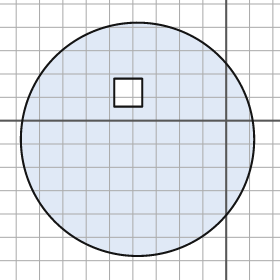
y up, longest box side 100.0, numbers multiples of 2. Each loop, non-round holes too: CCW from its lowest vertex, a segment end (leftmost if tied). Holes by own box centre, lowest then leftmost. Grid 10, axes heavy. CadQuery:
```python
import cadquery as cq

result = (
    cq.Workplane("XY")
    .moveTo(-38.0, -8.0)
    .circle(50.0)
    .moveTo(-48.0, 6.0)
    .lineTo(-36.0, 6.0)
    .lineTo(-36.0, 18.0)
    .lineTo(-48.0, 18.0)
    .close()
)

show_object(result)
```